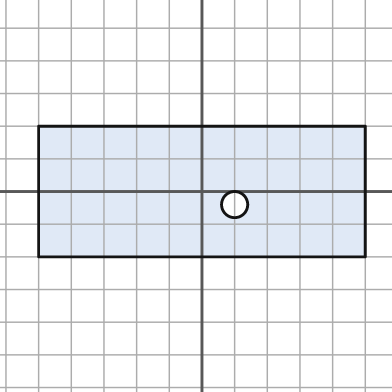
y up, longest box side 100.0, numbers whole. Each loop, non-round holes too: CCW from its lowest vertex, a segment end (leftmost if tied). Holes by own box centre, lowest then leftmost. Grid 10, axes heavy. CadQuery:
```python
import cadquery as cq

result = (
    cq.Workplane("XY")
    .moveTo(-50.0, -20.0)
    .lineTo(50.0, -20.0)
    .lineTo(50.0, 20.0)
    .lineTo(-50.0, 20.0)
    .close()
    .moveTo(10.0, -4.0)
    .circle(4.0)
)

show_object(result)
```